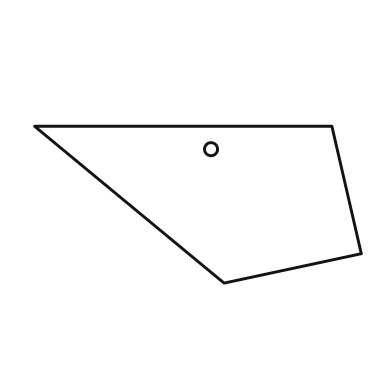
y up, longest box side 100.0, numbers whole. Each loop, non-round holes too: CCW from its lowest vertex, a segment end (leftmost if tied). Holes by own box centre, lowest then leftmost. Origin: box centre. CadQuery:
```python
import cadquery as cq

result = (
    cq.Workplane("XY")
    .moveTo(8.0, -24.0)
    .lineTo(50.0, -15.0)
    .lineTo(41.0, 24.0)
    .lineTo(-50.0, 24.0)
    .close()
    .moveTo(4.0, 17.0)
    .circle(2.0)
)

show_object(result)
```